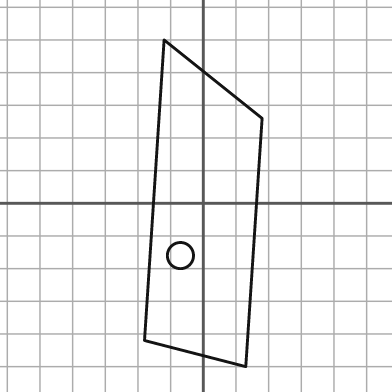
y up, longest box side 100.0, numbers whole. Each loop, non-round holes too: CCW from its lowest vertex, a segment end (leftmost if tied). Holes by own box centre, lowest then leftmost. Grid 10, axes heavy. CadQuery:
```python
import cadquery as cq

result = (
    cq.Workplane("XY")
    .moveTo(13.0, -50.0)
    .lineTo(18.0, 26.0)
    .lineTo(-12.0, 50.0)
    .lineTo(-18.0, -42.0)
    .close()
    .moveTo(-7.0, -16.0)
    .circle(4.0)
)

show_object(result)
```